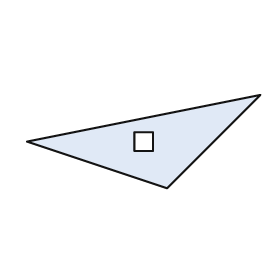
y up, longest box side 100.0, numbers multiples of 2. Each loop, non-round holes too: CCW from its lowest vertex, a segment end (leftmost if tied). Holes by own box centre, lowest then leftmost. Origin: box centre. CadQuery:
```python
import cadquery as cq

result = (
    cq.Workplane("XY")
    .moveTo(10.0, -20.0)
    .lineTo(50.0, 20.0)
    .lineTo(-50.0, 0.0)
    .close()
    .moveTo(-4.0, -4.0)
    .lineTo(4.0, -4.0)
    .lineTo(4.0, 4.0)
    .lineTo(-4.0, 4.0)
    .close()
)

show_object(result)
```